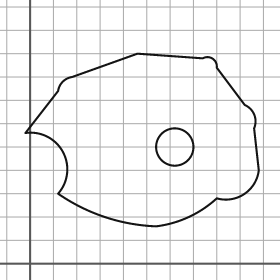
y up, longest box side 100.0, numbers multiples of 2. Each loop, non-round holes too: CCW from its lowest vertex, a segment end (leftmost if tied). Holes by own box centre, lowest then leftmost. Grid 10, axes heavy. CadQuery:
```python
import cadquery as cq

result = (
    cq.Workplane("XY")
    .moveTo(54.0, 16.0)
    .threePointArc((68.0, 20.0), (80.0, 28.0))
    .threePointArc((92.0, 30.0), (98.0, 40.0))
    .lineTo(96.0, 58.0)
    .threePointArc((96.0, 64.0), (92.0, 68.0))
    .lineTo(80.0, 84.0)
    .threePointArc((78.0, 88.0), (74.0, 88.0))
    .lineTo(46.0, 90.0)
    .lineTo(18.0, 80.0)
    .threePointArc((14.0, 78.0), (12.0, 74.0))
    .lineTo(-2.0, 56.0)
    .threePointArc((14.0, 48.0), (12.0, 30.0))
    .threePointArc((32.0, 20.0), (54.0, 16.0))
    .close()
    .moveTo(62.0, 50.0)
    .circle(8.0)
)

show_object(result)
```